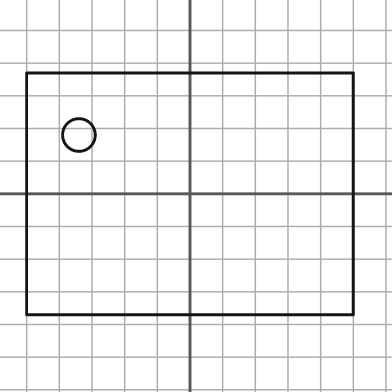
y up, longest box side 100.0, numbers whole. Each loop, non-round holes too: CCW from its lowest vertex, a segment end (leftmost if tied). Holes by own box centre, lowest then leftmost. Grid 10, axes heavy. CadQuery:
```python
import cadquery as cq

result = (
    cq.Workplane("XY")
    .moveTo(-50.0, -37.0)
    .lineTo(50.0, -37.0)
    .lineTo(50.0, 37.0)
    .lineTo(-50.0, 37.0)
    .close()
    .moveTo(-34.0, 18.0)
    .circle(5.0)
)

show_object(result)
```